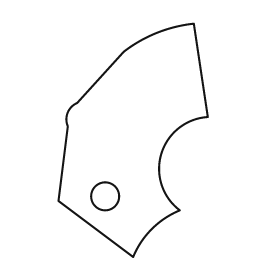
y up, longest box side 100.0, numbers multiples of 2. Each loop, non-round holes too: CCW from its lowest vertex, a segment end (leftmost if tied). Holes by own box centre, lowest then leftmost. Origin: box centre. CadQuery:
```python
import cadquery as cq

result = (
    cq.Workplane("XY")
    .moveTo(0.0, -50.0)
    .threePointArc((8.0, -38.0), (20.0, -30.0))
    .threePointArc((12.0, -6.0), (32.0, 10.0))
    .lineTo(26.0, 50.0)
    .threePointArc((10.0, 46.0), (-4.0, 38.0))
    .lineTo(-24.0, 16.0)
    .threePointArc((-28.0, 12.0), (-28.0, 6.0))
    .lineTo(-32.0, -26.0)
    .close()
    .moveTo(-12.0, -24.0)
    .circle(6.0)
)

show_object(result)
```